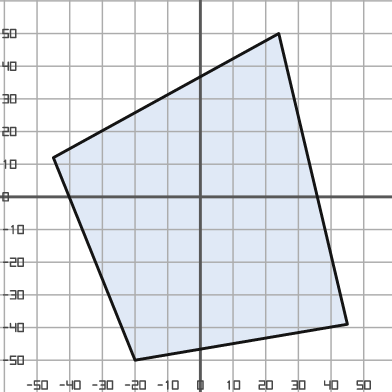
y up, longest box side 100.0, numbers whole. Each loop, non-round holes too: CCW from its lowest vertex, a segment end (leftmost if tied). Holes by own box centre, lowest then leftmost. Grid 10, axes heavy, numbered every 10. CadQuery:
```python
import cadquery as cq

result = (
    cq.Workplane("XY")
    .moveTo(-20.0, -50.0)
    .lineTo(45.0, -39.0)
    .lineTo(24.0, 50.0)
    .lineTo(-45.0, 12.0)
    .close()
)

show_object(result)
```